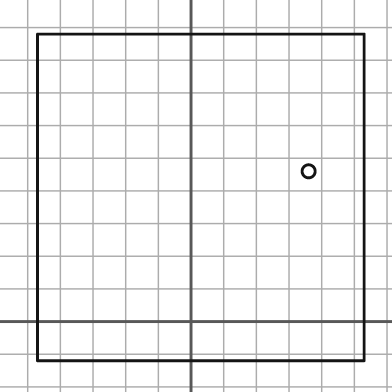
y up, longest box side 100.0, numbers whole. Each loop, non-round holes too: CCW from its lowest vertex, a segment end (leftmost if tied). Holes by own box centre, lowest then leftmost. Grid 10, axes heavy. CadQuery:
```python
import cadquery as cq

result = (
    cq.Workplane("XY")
    .moveTo(-47.0, -12.0)
    .lineTo(53.0, -12.0)
    .lineTo(53.0, 88.0)
    .lineTo(-47.0, 88.0)
    .close()
    .moveTo(36.0, 46.0)
    .circle(2.0)
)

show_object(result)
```